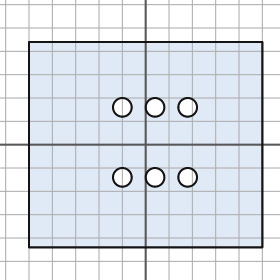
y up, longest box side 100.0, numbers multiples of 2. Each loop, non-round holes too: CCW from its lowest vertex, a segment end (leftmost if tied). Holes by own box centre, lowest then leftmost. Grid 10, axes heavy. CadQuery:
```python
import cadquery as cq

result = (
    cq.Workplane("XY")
    .moveTo(-50.0, -44.0)
    .lineTo(50.0, -44.0)
    .lineTo(50.0, 44.0)
    .lineTo(-50.0, 44.0)
    .close()
    .moveTo(-10.0, -14.0)
    .circle(4.0)
    .moveTo(4.0, -14.0)
    .circle(4.0)
    .moveTo(18.0, -14.0)
    .circle(4.0)
    .moveTo(-10.0, 16.0)
    .circle(4.0)
    .moveTo(4.0, 16.0)
    .circle(4.0)
    .moveTo(18.0, 16.0)
    .circle(4.0)
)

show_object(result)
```